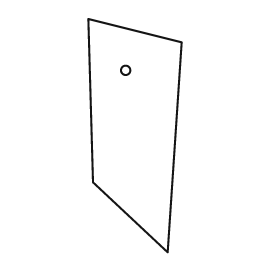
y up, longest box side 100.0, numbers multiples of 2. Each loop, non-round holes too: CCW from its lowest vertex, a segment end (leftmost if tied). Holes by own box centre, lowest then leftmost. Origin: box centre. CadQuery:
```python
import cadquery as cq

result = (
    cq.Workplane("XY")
    .moveTo(14.0, -50.0)
    .lineTo(20.0, 40.0)
    .lineTo(-20.0, 50.0)
    .lineTo(-18.0, -20.0)
    .close()
    .moveTo(-4.0, 28.0)
    .circle(2.0)
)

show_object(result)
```